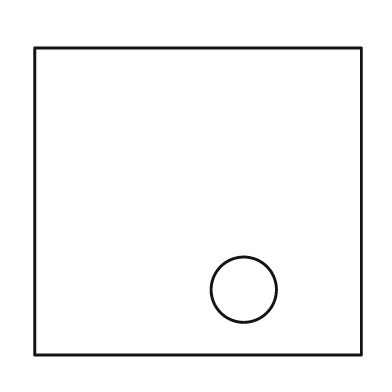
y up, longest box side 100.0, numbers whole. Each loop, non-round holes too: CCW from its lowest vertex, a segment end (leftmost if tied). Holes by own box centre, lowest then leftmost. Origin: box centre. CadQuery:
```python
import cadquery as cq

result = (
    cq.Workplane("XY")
    .moveTo(-50.0, -47.0)
    .lineTo(50.0, -47.0)
    .lineTo(50.0, 47.0)
    .lineTo(-50.0, 47.0)
    .close()
    .moveTo(14.0, -27.0)
    .circle(10.0)
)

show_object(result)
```